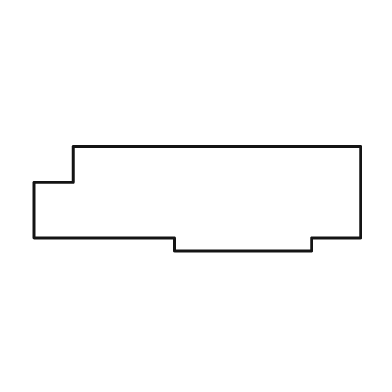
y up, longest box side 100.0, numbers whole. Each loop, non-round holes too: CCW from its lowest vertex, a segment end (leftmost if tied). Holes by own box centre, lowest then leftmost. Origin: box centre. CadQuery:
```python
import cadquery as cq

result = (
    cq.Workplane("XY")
    .moveTo(-7.0, -16.0)
    .lineTo(35.0, -16.0)
    .lineTo(35.0, -12.0)
    .lineTo(50.0, -12.0)
    .lineTo(50.0, 16.0)
    .lineTo(-38.0, 16.0)
    .lineTo(-38.0, 5.0)
    .lineTo(-50.0, 5.0)
    .lineTo(-50.0, -12.0)
    .lineTo(-7.0, -12.0)
    .close()
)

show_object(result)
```